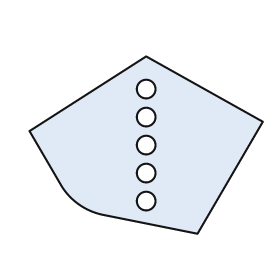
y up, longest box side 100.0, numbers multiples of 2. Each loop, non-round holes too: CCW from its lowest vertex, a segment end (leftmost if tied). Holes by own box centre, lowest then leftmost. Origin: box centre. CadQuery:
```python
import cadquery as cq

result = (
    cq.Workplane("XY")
    .moveTo(22.0, -38.0)
    .lineTo(50.0, 10.0)
    .lineTo(0.0, 38.0)
    .lineTo(-50.0, 6.0)
    .lineTo(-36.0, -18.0)
    .threePointArc((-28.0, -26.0), (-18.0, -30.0))
    .close()
    .moveTo(0.0, -24.0)
    .circle(4.0)
    .moveTo(0.0, -12.0)
    .circle(4.0)
    .moveTo(0.0, 0.0)
    .circle(4.0)
    .moveTo(0.0, 12.0)
    .circle(4.0)
    .moveTo(0.0, 24.0)
    .circle(4.0)
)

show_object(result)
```